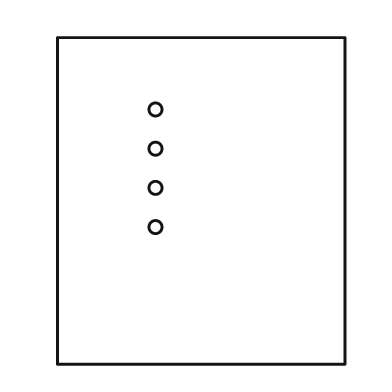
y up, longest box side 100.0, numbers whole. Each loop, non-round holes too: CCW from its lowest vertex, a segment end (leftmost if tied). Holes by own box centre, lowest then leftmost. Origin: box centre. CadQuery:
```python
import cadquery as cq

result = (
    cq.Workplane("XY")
    .moveTo(-44.0, -50.0)
    .lineTo(44.0, -50.0)
    .lineTo(44.0, 50.0)
    .lineTo(-44.0, 50.0)
    .close()
    .moveTo(-14.0, -8.0)
    .circle(2.0)
    .moveTo(-14.0, 4.0)
    .circle(2.0)
    .moveTo(-14.0, 16.0)
    .circle(2.0)
    .moveTo(-14.0, 28.0)
    .circle(2.0)
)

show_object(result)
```